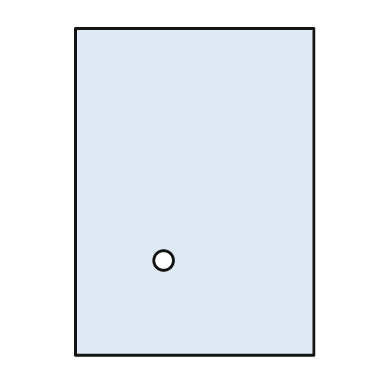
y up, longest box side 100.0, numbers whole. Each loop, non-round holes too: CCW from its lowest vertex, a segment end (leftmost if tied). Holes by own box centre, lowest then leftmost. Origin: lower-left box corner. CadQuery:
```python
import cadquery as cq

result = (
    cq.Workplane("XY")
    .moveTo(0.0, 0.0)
    .lineTo(73.0, 0.0)
    .lineTo(73.0, 100.0)
    .lineTo(0.0, 100.0)
    .close()
    .moveTo(27.0, 29.0)
    .circle(3.0)
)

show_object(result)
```